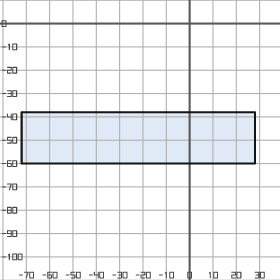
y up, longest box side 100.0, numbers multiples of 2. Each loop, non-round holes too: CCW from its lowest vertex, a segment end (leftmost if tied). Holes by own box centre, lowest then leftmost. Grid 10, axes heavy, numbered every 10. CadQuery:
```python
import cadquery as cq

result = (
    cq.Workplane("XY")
    .moveTo(-72.0, -60.0)
    .lineTo(28.0, -60.0)
    .lineTo(28.0, -38.0)
    .lineTo(-72.0, -38.0)
    .close()
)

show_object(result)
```